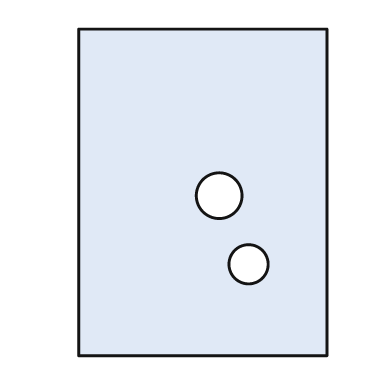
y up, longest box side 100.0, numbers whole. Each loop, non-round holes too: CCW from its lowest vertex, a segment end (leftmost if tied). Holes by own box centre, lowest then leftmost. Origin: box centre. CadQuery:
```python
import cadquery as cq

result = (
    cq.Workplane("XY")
    .moveTo(-38.0, -50.0)
    .lineTo(38.0, -50.0)
    .lineTo(38.0, 50.0)
    .lineTo(-38.0, 50.0)
    .close()
    .moveTo(14.0, -22.0)
    .circle(6.0)
    .moveTo(5.0, -1.0)
    .circle(7.0)
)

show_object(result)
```